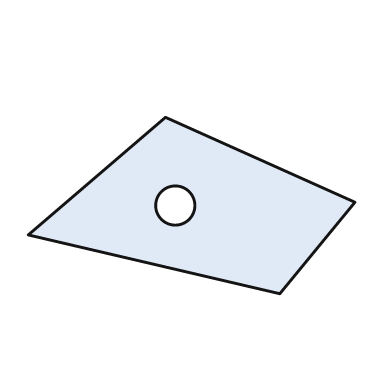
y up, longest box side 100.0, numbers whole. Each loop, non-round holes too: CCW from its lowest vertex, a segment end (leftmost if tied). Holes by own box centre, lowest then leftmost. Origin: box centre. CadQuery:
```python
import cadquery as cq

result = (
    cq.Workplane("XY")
    .moveTo(27.0, -27.0)
    .lineTo(50.0, 1.0)
    .lineTo(-8.0, 27.0)
    .lineTo(-50.0, -9.0)
    .close()
    .moveTo(-5.0, 0.0)
    .circle(6.0)
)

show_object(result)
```